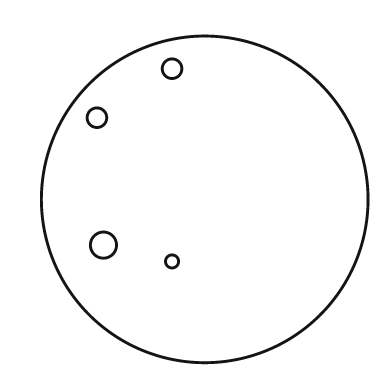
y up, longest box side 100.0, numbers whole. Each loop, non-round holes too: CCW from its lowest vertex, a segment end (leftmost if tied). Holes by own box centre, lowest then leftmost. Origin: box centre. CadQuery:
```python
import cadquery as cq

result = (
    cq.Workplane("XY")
    .moveTo(0.0, 0.0)
    .circle(50.0)
    .moveTo(-10.0, -19.0)
    .circle(2.0)
    .moveTo(-31.0, -14.0)
    .circle(4.0)
    .moveTo(-33.0, 25.0)
    .circle(3.0)
    .moveTo(-10.0, 40.0)
    .circle(3.0)
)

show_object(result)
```